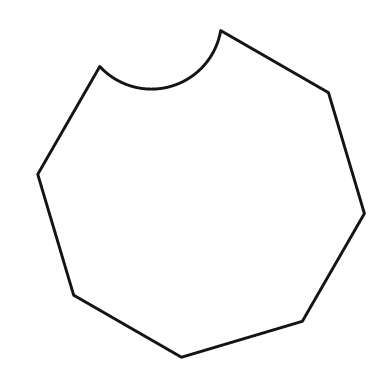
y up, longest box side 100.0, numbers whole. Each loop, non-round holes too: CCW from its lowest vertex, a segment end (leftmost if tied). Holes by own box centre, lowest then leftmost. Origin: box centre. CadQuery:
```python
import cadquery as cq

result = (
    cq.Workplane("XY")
    .moveTo(-6.0, -50.0)
    .lineTo(31.0, -39.0)
    .lineTo(50.0, -6.0)
    .lineTo(39.0, 31.0)
    .lineTo(6.0, 50.0)
    .threePointArc((-9.0, 33.0), (-31.0, 39.0))
    .lineTo(-50.0, 6.0)
    .lineTo(-39.0, -31.0)
    .close()
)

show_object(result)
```